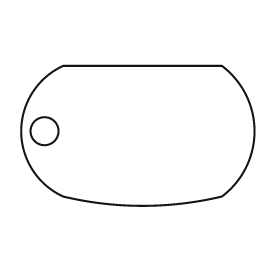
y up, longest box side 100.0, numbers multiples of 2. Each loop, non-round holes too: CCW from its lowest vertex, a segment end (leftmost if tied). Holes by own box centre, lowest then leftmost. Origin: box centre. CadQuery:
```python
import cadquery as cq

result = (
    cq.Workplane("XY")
    .moveTo(-32.0, -26.0)
    .threePointArc((2.0, -30.0), (36.0, -26.0))
    .threePointArc((50.0, 2.0), (36.0, 30.0))
    .lineTo(-32.0, 30.0)
    .threePointArc((-50.0, 2.0), (-32.0, -26.0))
    .close()
    .moveTo(-40.0, 2.0)
    .circle(6.0)
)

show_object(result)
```